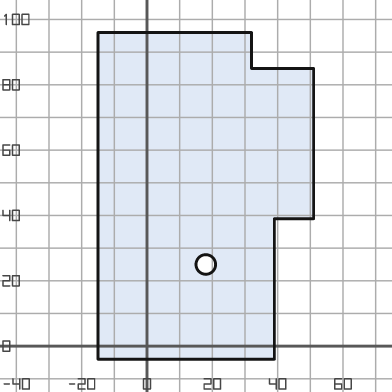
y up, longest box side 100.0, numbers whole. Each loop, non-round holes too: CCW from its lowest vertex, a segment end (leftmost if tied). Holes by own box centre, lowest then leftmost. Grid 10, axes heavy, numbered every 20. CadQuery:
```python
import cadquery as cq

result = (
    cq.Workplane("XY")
    .moveTo(-15.0, -4.0)
    .lineTo(39.0, -4.0)
    .lineTo(39.0, 39.0)
    .lineTo(51.0, 39.0)
    .lineTo(51.0, 85.0)
    .lineTo(32.0, 85.0)
    .lineTo(32.0, 96.0)
    .lineTo(-15.0, 96.0)
    .close()
    .moveTo(18.0, 25.0)
    .circle(3.0)
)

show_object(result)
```